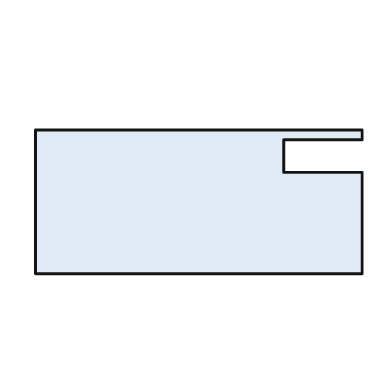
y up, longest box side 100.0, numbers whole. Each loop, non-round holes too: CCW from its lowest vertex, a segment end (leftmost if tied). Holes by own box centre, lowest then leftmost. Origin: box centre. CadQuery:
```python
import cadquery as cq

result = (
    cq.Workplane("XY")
    .moveTo(-50.0, -22.0)
    .lineTo(50.0, -22.0)
    .lineTo(50.0, 9.0)
    .lineTo(26.0, 9.0)
    .lineTo(26.0, 19.0)
    .lineTo(50.0, 19.0)
    .lineTo(50.0, 22.0)
    .lineTo(-50.0, 22.0)
    .close()
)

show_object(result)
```